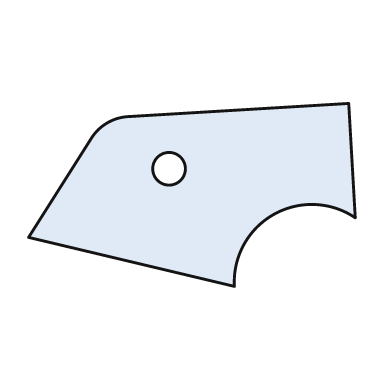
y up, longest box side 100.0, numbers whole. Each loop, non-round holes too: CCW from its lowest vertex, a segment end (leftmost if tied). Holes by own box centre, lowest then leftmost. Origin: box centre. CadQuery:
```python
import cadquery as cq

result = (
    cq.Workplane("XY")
    .moveTo(13.0, -28.0)
    .threePointArc((25.0, -6.0), (50.0, -7.0))
    .lineTo(48.0, 28.0)
    .lineTo(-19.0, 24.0)
    .threePointArc((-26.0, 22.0), (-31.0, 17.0))
    .lineTo(-50.0, -13.0)
    .close()
    .moveTo(-7.0, 8.0)
    .circle(5.0)
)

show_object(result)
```